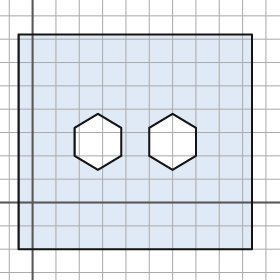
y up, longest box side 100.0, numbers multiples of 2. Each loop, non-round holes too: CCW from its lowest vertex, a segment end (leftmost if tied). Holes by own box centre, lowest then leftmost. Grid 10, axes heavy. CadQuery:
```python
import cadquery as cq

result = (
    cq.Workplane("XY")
    .moveTo(-6.0, -20.0)
    .lineTo(94.0, -20.0)
    .lineTo(94.0, 72.0)
    .lineTo(-6.0, 72.0)
    .close()
    .moveTo(28.0, 14.0)
    .lineTo(38.0, 20.0)
    .lineTo(38.0, 32.0)
    .lineTo(28.0, 38.0)
    .lineTo(18.0, 32.0)
    .lineTo(18.0, 20.0)
    .close()
    .moveTo(60.0, 14.0)
    .lineTo(70.0, 20.0)
    .lineTo(70.0, 32.0)
    .lineTo(60.0, 38.0)
    .lineTo(50.0, 32.0)
    .lineTo(50.0, 20.0)
    .close()
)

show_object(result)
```